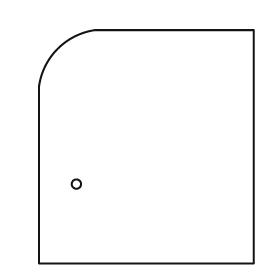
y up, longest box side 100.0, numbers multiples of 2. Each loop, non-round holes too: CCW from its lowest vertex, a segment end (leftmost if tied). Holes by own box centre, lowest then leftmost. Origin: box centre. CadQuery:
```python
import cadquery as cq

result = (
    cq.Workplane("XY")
    .moveTo(-46.0, -50.0)
    .lineTo(46.0, -50.0)
    .lineTo(46.0, 50.0)
    .lineTo(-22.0, 50.0)
    .threePointArc((-38.0, 42.0), (-46.0, 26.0))
    .close()
    .moveTo(-30.0, -16.0)
    .circle(2.0)
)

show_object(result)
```